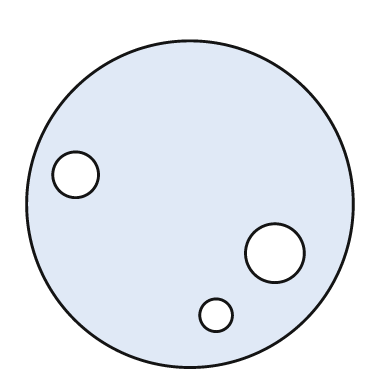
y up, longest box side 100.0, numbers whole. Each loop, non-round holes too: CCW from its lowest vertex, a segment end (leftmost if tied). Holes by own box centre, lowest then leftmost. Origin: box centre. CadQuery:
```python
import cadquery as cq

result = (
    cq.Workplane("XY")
    .moveTo(0.0, 0.0)
    .circle(50.0)
    .moveTo(8.0, -34.0)
    .circle(5.0)
    .moveTo(26.0, -15.0)
    .circle(9.0)
    .moveTo(-35.0, 9.0)
    .circle(7.0)
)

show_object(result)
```